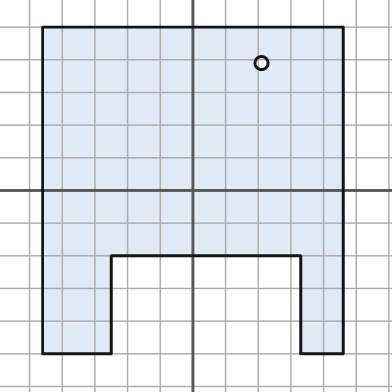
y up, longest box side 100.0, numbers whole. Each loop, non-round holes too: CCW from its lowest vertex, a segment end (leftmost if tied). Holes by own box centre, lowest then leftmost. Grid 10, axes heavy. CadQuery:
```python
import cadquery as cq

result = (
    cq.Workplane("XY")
    .moveTo(-46.0, -50.0)
    .lineTo(-25.0, -50.0)
    .lineTo(-25.0, -20.0)
    .lineTo(33.0, -20.0)
    .lineTo(33.0, -50.0)
    .lineTo(46.0, -50.0)
    .lineTo(46.0, 50.0)
    .lineTo(-46.0, 50.0)
    .close()
    .moveTo(21.0, 39.0)
    .circle(2.0)
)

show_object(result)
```